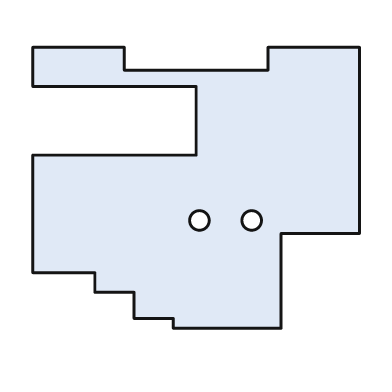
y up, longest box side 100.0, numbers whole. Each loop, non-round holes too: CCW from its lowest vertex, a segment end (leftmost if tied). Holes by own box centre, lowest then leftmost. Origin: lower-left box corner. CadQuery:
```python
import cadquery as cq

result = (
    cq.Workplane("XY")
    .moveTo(43.0, 0.0)
    .lineTo(76.0, 0.0)
    .lineTo(76.0, 29.0)
    .lineTo(100.0, 29.0)
    .lineTo(100.0, 86.0)
    .lineTo(72.0, 86.0)
    .lineTo(72.0, 79.0)
    .lineTo(28.0, 79.0)
    .lineTo(28.0, 86.0)
    .lineTo(0.0, 86.0)
    .lineTo(0.0, 74.0)
    .lineTo(50.0, 74.0)
    .lineTo(50.0, 53.0)
    .lineTo(0.0, 53.0)
    .lineTo(0.0, 17.0)
    .lineTo(19.0, 17.0)
    .lineTo(19.0, 11.0)
    .lineTo(31.0, 11.0)
    .lineTo(31.0, 3.0)
    .lineTo(43.0, 3.0)
    .close()
    .moveTo(51.0, 33.0)
    .circle(3.0)
    .moveTo(67.0, 33.0)
    .circle(3.0)
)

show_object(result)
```